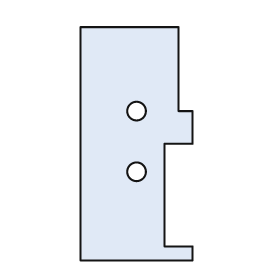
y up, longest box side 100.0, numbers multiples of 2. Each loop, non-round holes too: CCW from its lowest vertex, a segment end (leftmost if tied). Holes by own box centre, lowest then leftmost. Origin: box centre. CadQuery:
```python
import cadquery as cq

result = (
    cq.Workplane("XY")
    .moveTo(-24.0, -50.0)
    .lineTo(24.0, -50.0)
    .lineTo(24.0, -44.0)
    .lineTo(12.0, -44.0)
    .lineTo(12.0, 0.0)
    .lineTo(24.0, 0.0)
    .lineTo(24.0, 14.0)
    .lineTo(18.0, 14.0)
    .lineTo(18.0, 50.0)
    .lineTo(-24.0, 50.0)
    .close()
    .moveTo(0.0, -12.0)
    .circle(4.0)
    .moveTo(0.0, 14.0)
    .circle(4.0)
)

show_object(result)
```